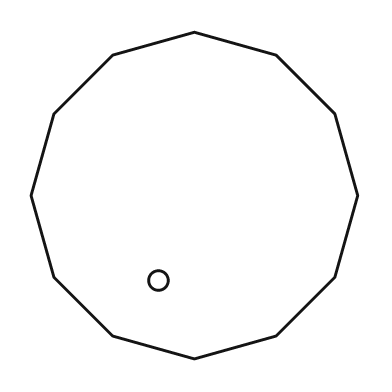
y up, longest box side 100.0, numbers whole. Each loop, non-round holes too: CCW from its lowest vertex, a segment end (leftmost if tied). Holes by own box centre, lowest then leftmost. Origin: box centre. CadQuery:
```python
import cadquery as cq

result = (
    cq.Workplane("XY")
    .moveTo(0.0, -50.0)
    .lineTo(25.0, -43.0)
    .lineTo(43.0, -25.0)
    .lineTo(50.0, 0.0)
    .lineTo(43.0, 25.0)
    .lineTo(25.0, 43.0)
    .lineTo(0.0, 50.0)
    .lineTo(-25.0, 43.0)
    .lineTo(-43.0, 25.0)
    .lineTo(-50.0, 0.0)
    .lineTo(-43.0, -25.0)
    .lineTo(-25.0, -43.0)
    .close()
    .moveTo(-11.0, -26.0)
    .circle(3.0)
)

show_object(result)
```